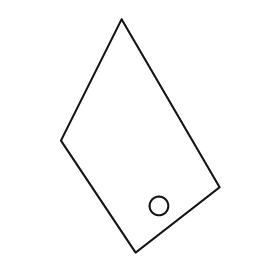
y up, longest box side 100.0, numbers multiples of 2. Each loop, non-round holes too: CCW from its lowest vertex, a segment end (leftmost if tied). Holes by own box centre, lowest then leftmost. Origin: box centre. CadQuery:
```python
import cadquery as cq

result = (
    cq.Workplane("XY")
    .moveTo(-2.0, -50.0)
    .lineTo(34.0, -22.0)
    .lineTo(-8.0, 50.0)
    .lineTo(-34.0, -2.0)
    .close()
    .moveTo(8.0, -30.0)
    .circle(4.0)
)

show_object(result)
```